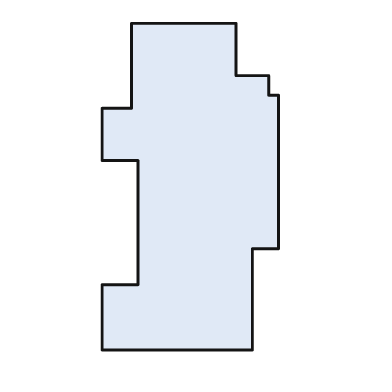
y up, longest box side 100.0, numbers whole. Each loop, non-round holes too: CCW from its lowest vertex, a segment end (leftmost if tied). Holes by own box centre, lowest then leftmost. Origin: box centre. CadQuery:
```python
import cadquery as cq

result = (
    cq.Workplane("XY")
    .moveTo(-27.0, -50.0)
    .lineTo(19.0, -50.0)
    .lineTo(19.0, -19.0)
    .lineTo(27.0, -19.0)
    .lineTo(27.0, 28.0)
    .lineTo(24.0, 28.0)
    .lineTo(24.0, 34.0)
    .lineTo(14.0, 34.0)
    .lineTo(14.0, 50.0)
    .lineTo(-18.0, 50.0)
    .lineTo(-18.0, 24.0)
    .lineTo(-27.0, 24.0)
    .lineTo(-27.0, 8.0)
    .lineTo(-16.0, 8.0)
    .lineTo(-16.0, -30.0)
    .lineTo(-27.0, -30.0)
    .close()
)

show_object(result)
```